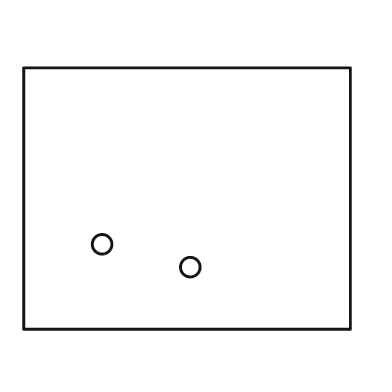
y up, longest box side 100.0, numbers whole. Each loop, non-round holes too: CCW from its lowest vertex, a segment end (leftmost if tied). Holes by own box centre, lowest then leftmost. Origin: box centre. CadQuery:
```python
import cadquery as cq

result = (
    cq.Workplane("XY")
    .moveTo(-50.0, -40.0)
    .lineTo(50.0, -40.0)
    .lineTo(50.0, 40.0)
    .lineTo(-50.0, 40.0)
    .close()
    .moveTo(1.0, -21.0)
    .circle(3.0)
    .moveTo(-26.0, -14.0)
    .circle(3.0)
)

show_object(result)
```